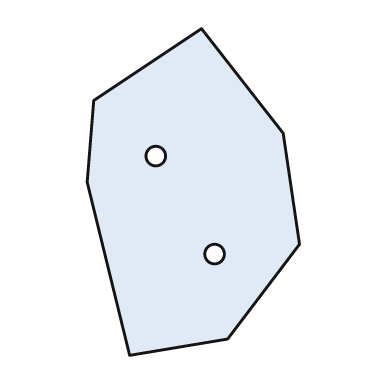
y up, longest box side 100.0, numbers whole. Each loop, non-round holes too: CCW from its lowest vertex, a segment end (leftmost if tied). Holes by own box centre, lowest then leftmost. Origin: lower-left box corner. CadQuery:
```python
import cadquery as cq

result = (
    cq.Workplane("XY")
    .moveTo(13.0, 0.0)
    .lineTo(43.0, 5.0)
    .lineTo(65.0, 34.0)
    .lineTo(60.0, 68.0)
    .lineTo(35.0, 100.0)
    .lineTo(2.0, 78.0)
    .lineTo(0.0, 53.0)
    .close()
    .moveTo(39.0, 31.0)
    .circle(3.0)
    .moveTo(21.0, 61.0)
    .circle(3.0)
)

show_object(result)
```